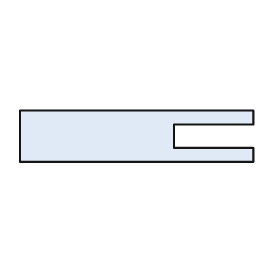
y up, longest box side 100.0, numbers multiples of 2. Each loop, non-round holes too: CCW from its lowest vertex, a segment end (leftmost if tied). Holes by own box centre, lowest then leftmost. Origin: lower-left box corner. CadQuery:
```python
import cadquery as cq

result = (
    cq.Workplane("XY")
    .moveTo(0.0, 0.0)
    .lineTo(100.0, 0.0)
    .lineTo(100.0, 6.0)
    .lineTo(66.0, 6.0)
    .lineTo(66.0, 16.0)
    .lineTo(100.0, 16.0)
    .lineTo(100.0, 22.0)
    .lineTo(0.0, 22.0)
    .close()
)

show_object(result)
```